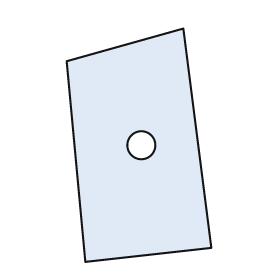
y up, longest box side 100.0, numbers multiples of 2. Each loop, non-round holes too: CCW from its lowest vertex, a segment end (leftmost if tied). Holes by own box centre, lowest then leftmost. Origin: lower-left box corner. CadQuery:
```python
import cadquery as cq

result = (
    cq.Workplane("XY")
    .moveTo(8.0, 0.0)
    .lineTo(62.0, 6.0)
    .lineTo(50.0, 100.0)
    .lineTo(0.0, 86.0)
    .close()
    .moveTo(32.0, 50.0)
    .circle(6.0)
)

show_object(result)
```